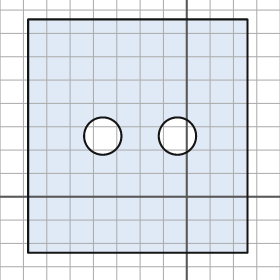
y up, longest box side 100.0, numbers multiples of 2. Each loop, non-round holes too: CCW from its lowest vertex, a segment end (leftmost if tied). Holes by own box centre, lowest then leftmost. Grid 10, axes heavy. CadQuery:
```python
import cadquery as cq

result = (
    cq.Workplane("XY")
    .moveTo(-68.0, -24.0)
    .lineTo(26.0, -24.0)
    .lineTo(26.0, 76.0)
    .lineTo(-68.0, 76.0)
    .close()
    .moveTo(-36.0, 26.0)
    .circle(8.0)
    .moveTo(-4.0, 26.0)
    .circle(8.0)
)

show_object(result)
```